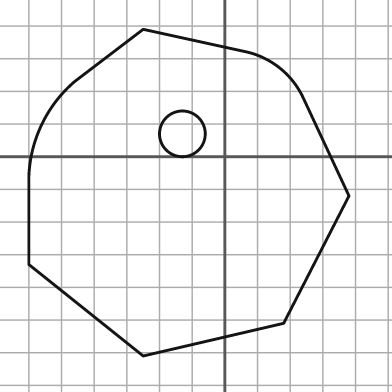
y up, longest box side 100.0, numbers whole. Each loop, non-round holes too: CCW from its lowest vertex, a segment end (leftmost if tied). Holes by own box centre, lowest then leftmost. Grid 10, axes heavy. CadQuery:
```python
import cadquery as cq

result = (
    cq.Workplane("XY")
    .moveTo(-25.0, -61.0)
    .lineTo(18.0, -51.0)
    .lineTo(38.0, -12.0)
    .lineTo(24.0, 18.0)
    .threePointArc((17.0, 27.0), (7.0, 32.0))
    .lineTo(-25.0, 39.0)
    .lineTo(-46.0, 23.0)
    .threePointArc((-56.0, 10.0), (-60.0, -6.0))
    .lineTo(-60.0, -33.0)
    .close()
    .moveTo(-13.0, 7.0)
    .circle(7.0)
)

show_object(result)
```